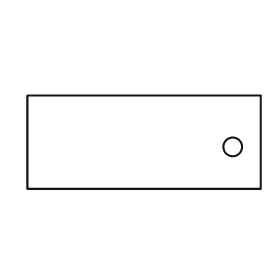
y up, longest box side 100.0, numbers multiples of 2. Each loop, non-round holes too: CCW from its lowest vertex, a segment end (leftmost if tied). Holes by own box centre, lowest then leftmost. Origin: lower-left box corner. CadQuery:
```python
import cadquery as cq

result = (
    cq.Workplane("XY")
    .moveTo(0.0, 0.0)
    .lineTo(100.0, 0.0)
    .lineTo(100.0, 40.0)
    .lineTo(0.0, 40.0)
    .close()
    .moveTo(88.0, 18.0)
    .circle(4.0)
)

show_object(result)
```